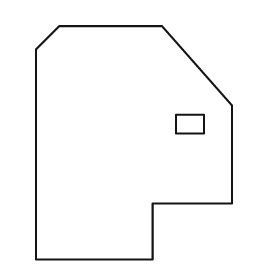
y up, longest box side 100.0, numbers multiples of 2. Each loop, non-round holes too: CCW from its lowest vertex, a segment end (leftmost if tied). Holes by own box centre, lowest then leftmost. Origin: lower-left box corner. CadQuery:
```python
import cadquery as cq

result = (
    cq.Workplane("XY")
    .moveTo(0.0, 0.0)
    .lineTo(50.0, 0.0)
    .lineTo(50.0, 24.0)
    .lineTo(84.0, 24.0)
    .lineTo(84.0, 66.0)
    .lineTo(54.0, 100.0)
    .lineTo(10.0, 100.0)
    .lineTo(0.0, 90.0)
    .close()
    .moveTo(60.0, 54.0)
    .lineTo(72.0, 54.0)
    .lineTo(72.0, 62.0)
    .lineTo(60.0, 62.0)
    .close()
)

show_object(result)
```